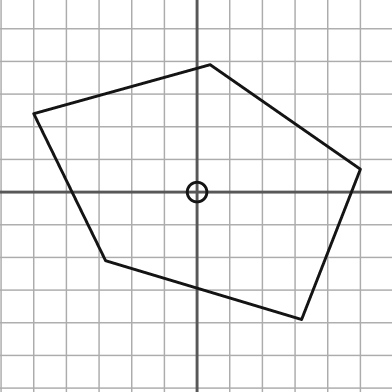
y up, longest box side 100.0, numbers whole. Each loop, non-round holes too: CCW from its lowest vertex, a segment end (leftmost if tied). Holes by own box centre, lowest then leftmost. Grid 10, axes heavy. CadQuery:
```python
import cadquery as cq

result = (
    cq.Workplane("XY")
    .moveTo(32.0, -39.0)
    .lineTo(50.0, 7.0)
    .lineTo(4.0, 39.0)
    .lineTo(-50.0, 24.0)
    .lineTo(-28.0, -21.0)
    .close()
    .moveTo(0.0, 0.0)
    .circle(3.0)
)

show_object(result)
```